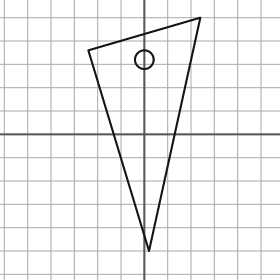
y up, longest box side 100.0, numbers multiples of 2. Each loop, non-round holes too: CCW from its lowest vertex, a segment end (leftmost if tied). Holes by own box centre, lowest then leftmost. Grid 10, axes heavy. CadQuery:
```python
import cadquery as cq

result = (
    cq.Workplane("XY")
    .moveTo(2.0, -50.0)
    .lineTo(24.0, 50.0)
    .lineTo(-24.0, 36.0)
    .close()
    .moveTo(0.0, 32.0)
    .circle(4.0)
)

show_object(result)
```